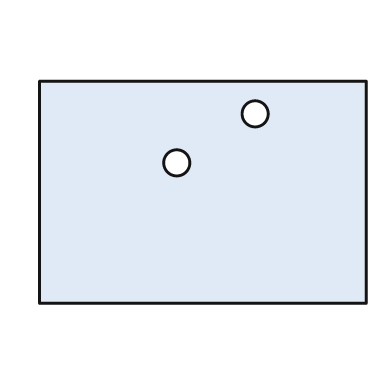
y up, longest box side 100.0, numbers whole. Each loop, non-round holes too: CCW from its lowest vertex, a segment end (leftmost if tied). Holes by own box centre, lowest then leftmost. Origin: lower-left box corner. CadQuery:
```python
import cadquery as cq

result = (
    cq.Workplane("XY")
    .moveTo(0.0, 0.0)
    .lineTo(100.0, 0.0)
    .lineTo(100.0, 68.0)
    .lineTo(0.0, 68.0)
    .close()
    .moveTo(42.0, 43.0)
    .circle(4.0)
    .moveTo(66.0, 58.0)
    .circle(4.0)
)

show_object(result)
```